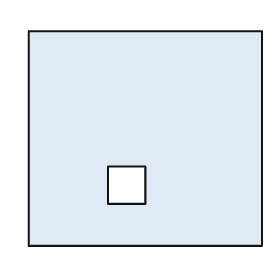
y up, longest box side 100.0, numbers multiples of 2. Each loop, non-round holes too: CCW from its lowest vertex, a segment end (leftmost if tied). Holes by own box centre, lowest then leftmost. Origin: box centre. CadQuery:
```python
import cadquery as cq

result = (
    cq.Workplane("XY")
    .moveTo(-50.0, -46.0)
    .lineTo(50.0, -46.0)
    .lineTo(50.0, 46.0)
    .lineTo(-50.0, 46.0)
    .close()
    .moveTo(-16.0, -28.0)
    .lineTo(0.0, -28.0)
    .lineTo(0.0, -12.0)
    .lineTo(-16.0, -12.0)
    .close()
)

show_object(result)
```